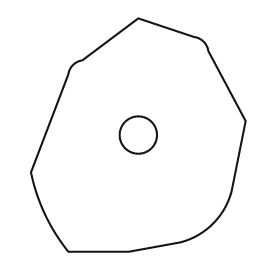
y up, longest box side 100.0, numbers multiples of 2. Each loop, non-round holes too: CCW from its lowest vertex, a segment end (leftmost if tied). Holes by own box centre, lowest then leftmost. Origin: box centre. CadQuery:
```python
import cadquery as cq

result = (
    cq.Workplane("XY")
    .moveTo(-30.0, -50.0)
    .lineTo(-4.0, -50.0)
    .lineTo(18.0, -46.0)
    .threePointArc((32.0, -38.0), (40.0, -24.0))
    .lineTo(46.0, 6.0)
    .lineTo(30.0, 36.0)
    .threePointArc((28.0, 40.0), (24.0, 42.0))
    .lineTo(0.0, 50.0)
    .lineTo(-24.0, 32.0)
    .threePointArc((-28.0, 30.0), (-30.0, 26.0))
    .lineTo(-46.0, -16.0)
    .threePointArc((-40.0, -34.0), (-30.0, -50.0))
    .close()
    .moveTo(0.0, 0.0)
    .circle(8.0)
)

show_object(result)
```